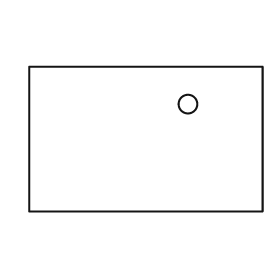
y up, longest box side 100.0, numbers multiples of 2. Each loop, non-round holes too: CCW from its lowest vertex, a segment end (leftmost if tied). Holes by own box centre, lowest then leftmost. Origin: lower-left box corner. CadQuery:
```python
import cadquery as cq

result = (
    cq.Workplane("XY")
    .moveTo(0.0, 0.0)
    .lineTo(100.0, 0.0)
    .lineTo(100.0, 62.0)
    .lineTo(0.0, 62.0)
    .close()
    .moveTo(68.0, 46.0)
    .circle(4.0)
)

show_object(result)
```